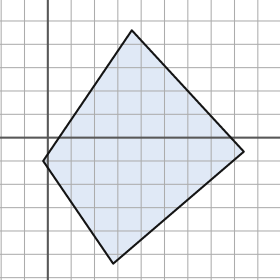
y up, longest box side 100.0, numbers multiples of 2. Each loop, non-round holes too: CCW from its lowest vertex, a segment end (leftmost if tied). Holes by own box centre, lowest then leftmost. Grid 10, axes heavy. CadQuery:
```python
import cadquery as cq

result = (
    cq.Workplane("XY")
    .moveTo(28.0, -54.0)
    .lineTo(84.0, -6.0)
    .lineTo(36.0, 46.0)
    .lineTo(-2.0, -10.0)
    .close()
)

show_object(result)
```